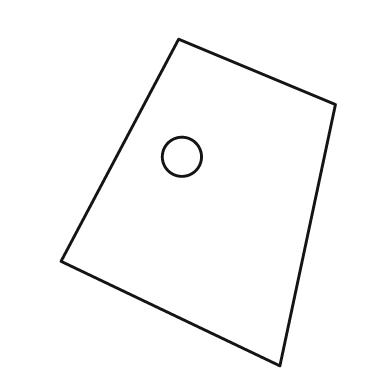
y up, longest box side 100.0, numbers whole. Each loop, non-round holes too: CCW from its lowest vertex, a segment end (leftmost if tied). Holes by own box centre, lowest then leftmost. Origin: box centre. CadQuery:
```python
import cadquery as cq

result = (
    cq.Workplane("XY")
    .moveTo(25.0, -50.0)
    .lineTo(42.0, 30.0)
    .lineTo(-6.0, 50.0)
    .lineTo(-42.0, -18.0)
    .close()
    .moveTo(-5.0, 14.0)
    .circle(6.0)
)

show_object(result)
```